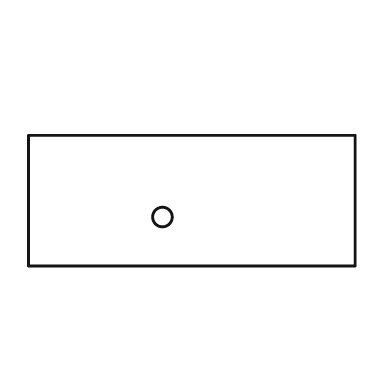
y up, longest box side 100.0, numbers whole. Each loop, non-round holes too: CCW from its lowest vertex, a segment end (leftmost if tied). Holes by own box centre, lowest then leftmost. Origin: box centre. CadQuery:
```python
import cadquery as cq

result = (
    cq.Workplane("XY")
    .moveTo(-50.0, -20.0)
    .lineTo(50.0, -20.0)
    .lineTo(50.0, 20.0)
    .lineTo(-50.0, 20.0)
    .close()
    .moveTo(-9.0, -5.0)
    .circle(3.0)
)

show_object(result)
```